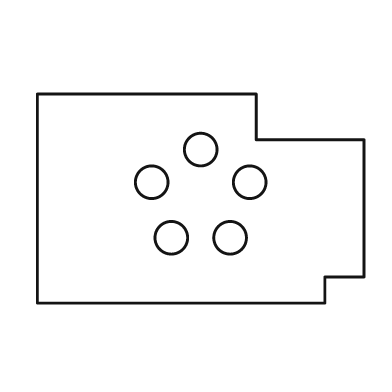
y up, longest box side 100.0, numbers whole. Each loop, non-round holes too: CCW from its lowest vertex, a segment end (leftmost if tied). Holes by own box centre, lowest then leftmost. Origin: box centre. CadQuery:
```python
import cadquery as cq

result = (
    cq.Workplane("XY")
    .moveTo(-50.0, -32.0)
    .lineTo(38.0, -32.0)
    .lineTo(38.0, -24.0)
    .lineTo(50.0, -24.0)
    .lineTo(50.0, 18.0)
    .lineTo(17.0, 18.0)
    .lineTo(17.0, 32.0)
    .lineTo(-50.0, 32.0)
    .close()
    .moveTo(-9.0, -12.0)
    .circle(5.0)
    .moveTo(9.0, -12.0)
    .circle(5.0)
    .moveTo(-15.0, 5.0)
    .circle(5.0)
    .moveTo(15.0, 5.0)
    .circle(5.0)
    .moveTo(0.0, 15.0)
    .circle(5.0)
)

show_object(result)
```